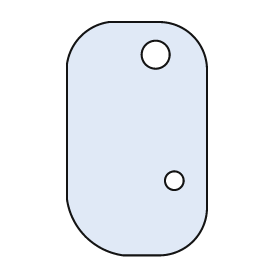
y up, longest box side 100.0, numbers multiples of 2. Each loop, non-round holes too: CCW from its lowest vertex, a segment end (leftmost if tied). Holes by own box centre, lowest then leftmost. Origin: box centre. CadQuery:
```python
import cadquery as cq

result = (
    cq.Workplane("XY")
    .moveTo(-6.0, -50.0)
    .lineTo(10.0, -50.0)
    .threePointArc((24.0, -44.0), (30.0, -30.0))
    .lineTo(30.0, 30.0)
    .threePointArc((24.0, 44.0), (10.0, 50.0))
    .lineTo(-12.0, 50.0)
    .threePointArc((-24.0, 44.0), (-30.0, 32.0))
    .lineTo(-30.0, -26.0)
    .threePointArc((-22.0, -42.0), (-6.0, -50.0))
    .close()
    .moveTo(16.0, -18.0)
    .circle(4.0)
    .moveTo(8.0, 36.0)
    .circle(6.0)
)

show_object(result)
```